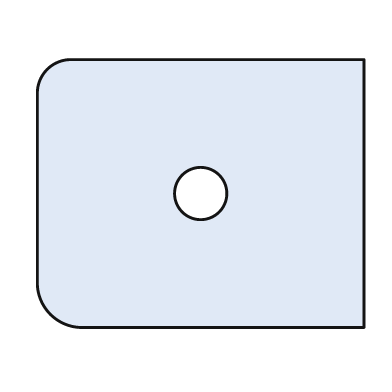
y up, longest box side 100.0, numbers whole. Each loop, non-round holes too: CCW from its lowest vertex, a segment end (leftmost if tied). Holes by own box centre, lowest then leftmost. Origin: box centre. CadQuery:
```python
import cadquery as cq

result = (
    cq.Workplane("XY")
    .moveTo(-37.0, -41.0)
    .lineTo(50.0, -41.0)
    .lineTo(50.0, 41.0)
    .lineTo(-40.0, 41.0)
    .threePointArc((-47.0, 38.0), (-50.0, 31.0))
    .lineTo(-50.0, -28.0)
    .threePointArc((-46.0, -37.0), (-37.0, -41.0))
    .close()
    .moveTo(0.0, 0.0)
    .circle(8.0)
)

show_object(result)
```